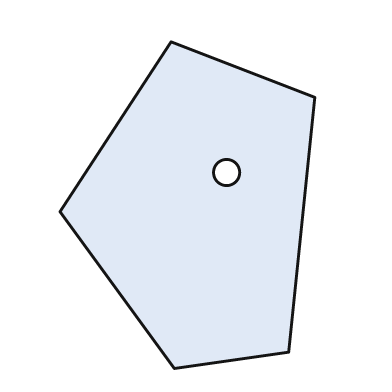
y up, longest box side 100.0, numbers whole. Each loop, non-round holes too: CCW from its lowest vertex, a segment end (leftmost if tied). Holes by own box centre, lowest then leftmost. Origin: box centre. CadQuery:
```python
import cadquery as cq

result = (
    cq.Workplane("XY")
    .moveTo(-4.0, -50.0)
    .lineTo(31.0, -45.0)
    .lineTo(39.0, 33.0)
    .lineTo(-5.0, 50.0)
    .lineTo(-39.0, -2.0)
    .close()
    .moveTo(12.0, 10.0)
    .circle(4.0)
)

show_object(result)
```